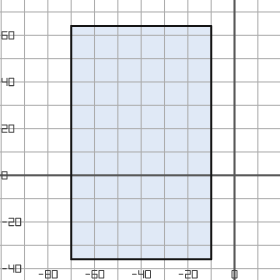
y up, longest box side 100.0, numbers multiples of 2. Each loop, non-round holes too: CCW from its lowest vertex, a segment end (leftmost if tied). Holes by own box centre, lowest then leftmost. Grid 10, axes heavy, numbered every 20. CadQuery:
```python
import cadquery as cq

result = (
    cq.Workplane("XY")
    .moveTo(-70.0, -36.0)
    .lineTo(-10.0, -36.0)
    .lineTo(-10.0, 64.0)
    .lineTo(-70.0, 64.0)
    .close()
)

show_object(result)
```